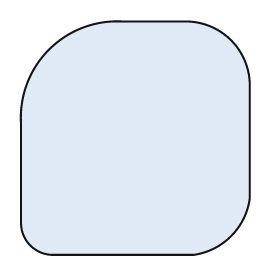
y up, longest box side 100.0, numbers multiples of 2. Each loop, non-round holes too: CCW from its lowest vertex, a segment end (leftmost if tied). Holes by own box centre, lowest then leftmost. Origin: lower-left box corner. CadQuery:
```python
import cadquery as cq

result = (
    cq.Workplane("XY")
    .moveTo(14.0, 0.0)
    .lineTo(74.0, 0.0)
    .threePointArc((90.0, 8.0), (98.0, 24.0))
    .lineTo(98.0, 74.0)
    .threePointArc((90.0, 92.0), (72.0, 100.0))
    .lineTo(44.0, 100.0)
    .threePointArc((12.0, 88.0), (0.0, 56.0))
    .lineTo(0.0, 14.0)
    .threePointArc((4.0, 4.0), (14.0, 0.0))
    .close()
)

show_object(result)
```